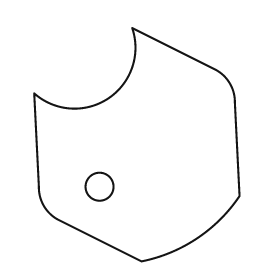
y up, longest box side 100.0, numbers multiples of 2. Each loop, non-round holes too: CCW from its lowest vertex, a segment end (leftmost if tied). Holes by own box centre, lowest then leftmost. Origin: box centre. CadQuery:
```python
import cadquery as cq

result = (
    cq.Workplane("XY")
    .moveTo(2.0, -50.0)
    .threePointArc((26.0, -40.0), (44.0, -22.0))
    .lineTo(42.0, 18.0)
    .threePointArc((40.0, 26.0), (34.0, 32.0))
    .lineTo(-2.0, 50.0)
    .threePointArc((-12.0, 20.0), (-44.0, 22.0))
    .lineTo(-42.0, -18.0)
    .threePointArc((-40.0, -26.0), (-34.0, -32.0))
    .close()
    .moveTo(-16.0, -18.0)
    .circle(6.0)
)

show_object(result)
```